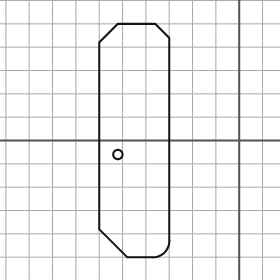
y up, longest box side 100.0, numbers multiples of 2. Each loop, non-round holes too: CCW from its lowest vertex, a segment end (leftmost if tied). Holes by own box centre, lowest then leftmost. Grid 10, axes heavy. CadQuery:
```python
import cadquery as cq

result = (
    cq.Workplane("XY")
    .moveTo(-48.0, -50.0)
    .lineTo(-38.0, -50.0)
    .threePointArc((-32.0, -48.0), (-30.0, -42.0))
    .lineTo(-30.0, 44.0)
    .lineTo(-36.0, 50.0)
    .lineTo(-52.0, 50.0)
    .lineTo(-60.0, 42.0)
    .lineTo(-60.0, -38.0)
    .close()
    .moveTo(-52.0, -6.0)
    .circle(2.0)
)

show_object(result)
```